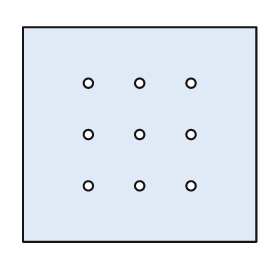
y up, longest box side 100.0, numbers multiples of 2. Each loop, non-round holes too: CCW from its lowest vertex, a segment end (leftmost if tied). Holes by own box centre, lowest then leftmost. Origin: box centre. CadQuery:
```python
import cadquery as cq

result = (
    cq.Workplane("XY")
    .moveTo(-50.0, -46.0)
    .lineTo(50.0, -46.0)
    .lineTo(50.0, 46.0)
    .lineTo(-50.0, 46.0)
    .close()
    .moveTo(-22.0, -22.0)
    .circle(2.0)
    .moveTo(0.0, -22.0)
    .circle(2.0)
    .moveTo(22.0, -22.0)
    .circle(2.0)
    .moveTo(-22.0, 0.0)
    .circle(2.0)
    .moveTo(0.0, 0.0)
    .circle(2.0)
    .moveTo(22.0, 0.0)
    .circle(2.0)
    .moveTo(-22.0, 22.0)
    .circle(2.0)
    .moveTo(0.0, 22.0)
    .circle(2.0)
    .moveTo(22.0, 22.0)
    .circle(2.0)
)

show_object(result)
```